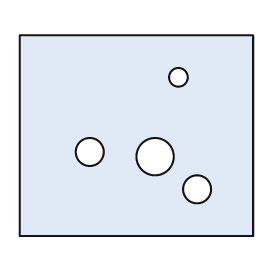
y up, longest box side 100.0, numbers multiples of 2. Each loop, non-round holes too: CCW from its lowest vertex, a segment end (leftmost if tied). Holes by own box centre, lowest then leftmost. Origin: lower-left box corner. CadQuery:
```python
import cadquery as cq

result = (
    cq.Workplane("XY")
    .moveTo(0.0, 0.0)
    .lineTo(100.0, 0.0)
    .lineTo(100.0, 86.0)
    .lineTo(0.0, 86.0)
    .close()
    .moveTo(76.0, 20.0)
    .circle(6.0)
    .moveTo(58.0, 34.0)
    .circle(8.0)
    .moveTo(30.0, 36.0)
    .circle(6.0)
    .moveTo(68.0, 68.0)
    .circle(4.0)
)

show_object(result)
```